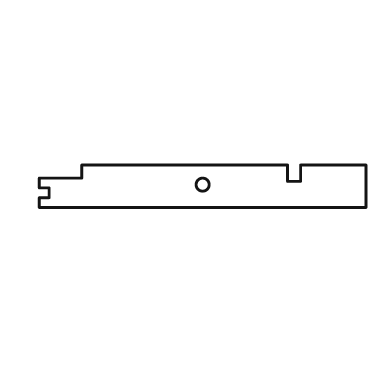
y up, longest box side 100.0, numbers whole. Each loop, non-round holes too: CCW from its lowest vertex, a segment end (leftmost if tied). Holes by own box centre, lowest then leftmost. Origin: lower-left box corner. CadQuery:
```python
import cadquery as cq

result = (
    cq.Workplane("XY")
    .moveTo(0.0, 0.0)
    .lineTo(100.0, 0.0)
    .lineTo(100.0, 13.0)
    .lineTo(80.0, 13.0)
    .lineTo(80.0, 8.0)
    .lineTo(76.0, 8.0)
    .lineTo(76.0, 13.0)
    .lineTo(13.0, 13.0)
    .lineTo(13.0, 9.0)
    .lineTo(0.0, 9.0)
    .lineTo(0.0, 6.0)
    .lineTo(3.0, 6.0)
    .lineTo(3.0, 3.0)
    .lineTo(0.0, 3.0)
    .close()
    .moveTo(50.0, 7.0)
    .circle(2.0)
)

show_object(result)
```